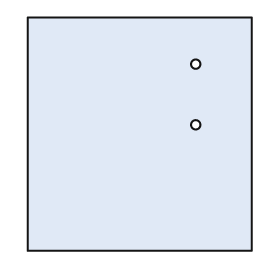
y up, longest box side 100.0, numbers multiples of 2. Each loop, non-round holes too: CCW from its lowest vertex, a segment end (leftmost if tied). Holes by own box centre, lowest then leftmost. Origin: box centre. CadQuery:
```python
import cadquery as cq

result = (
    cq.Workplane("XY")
    .moveTo(-48.0, -50.0)
    .lineTo(48.0, -50.0)
    .lineTo(48.0, 50.0)
    .lineTo(-48.0, 50.0)
    .close()
    .moveTo(24.0, 4.0)
    .circle(2.0)
    .moveTo(24.0, 30.0)
    .circle(2.0)
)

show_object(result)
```